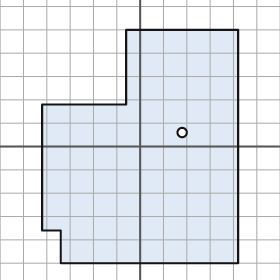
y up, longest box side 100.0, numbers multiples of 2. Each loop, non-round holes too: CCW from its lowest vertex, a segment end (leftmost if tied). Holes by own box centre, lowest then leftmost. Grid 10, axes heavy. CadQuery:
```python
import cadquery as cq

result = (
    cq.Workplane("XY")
    .moveTo(-34.0, -50.0)
    .lineTo(42.0, -50.0)
    .lineTo(42.0, 50.0)
    .lineTo(-6.0, 50.0)
    .lineTo(-6.0, 18.0)
    .lineTo(-42.0, 18.0)
    .lineTo(-42.0, -36.0)
    .lineTo(-34.0, -36.0)
    .close()
    .moveTo(18.0, 6.0)
    .circle(2.0)
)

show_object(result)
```